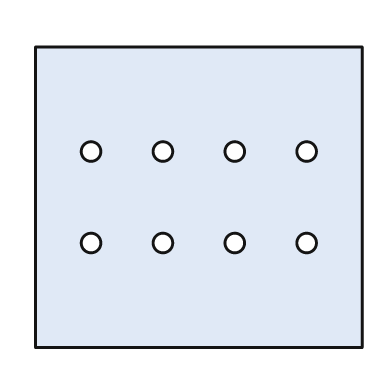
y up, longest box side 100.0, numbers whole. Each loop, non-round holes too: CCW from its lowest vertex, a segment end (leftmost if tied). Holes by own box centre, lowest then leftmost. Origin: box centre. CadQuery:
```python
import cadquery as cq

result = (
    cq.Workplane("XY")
    .moveTo(-50.0, -46.0)
    .lineTo(50.0, -46.0)
    .lineTo(50.0, 46.0)
    .lineTo(-50.0, 46.0)
    .close()
    .moveTo(-33.0, -14.0)
    .circle(3.0)
    .moveTo(-11.0, -14.0)
    .circle(3.0)
    .moveTo(11.0, -14.0)
    .circle(3.0)
    .moveTo(33.0, -14.0)
    .circle(3.0)
    .moveTo(-33.0, 14.0)
    .circle(3.0)
    .moveTo(-11.0, 14.0)
    .circle(3.0)
    .moveTo(11.0, 14.0)
    .circle(3.0)
    .moveTo(33.0, 14.0)
    .circle(3.0)
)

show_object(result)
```